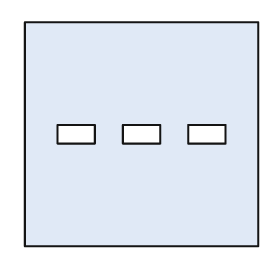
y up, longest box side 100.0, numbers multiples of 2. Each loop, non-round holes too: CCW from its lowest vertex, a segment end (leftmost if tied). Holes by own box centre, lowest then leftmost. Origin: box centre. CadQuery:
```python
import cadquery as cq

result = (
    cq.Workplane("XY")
    .moveTo(-50.0, -48.0)
    .lineTo(50.0, -48.0)
    .lineTo(50.0, 48.0)
    .lineTo(-50.0, 48.0)
    .close()
    .moveTo(-36.0, -4.0)
    .lineTo(-20.0, -4.0)
    .lineTo(-20.0, 4.0)
    .lineTo(-36.0, 4.0)
    .close()
    .moveTo(-8.0, -4.0)
    .lineTo(8.0, -4.0)
    .lineTo(8.0, 4.0)
    .lineTo(-8.0, 4.0)
    .close()
    .moveTo(20.0, -4.0)
    .lineTo(36.0, -4.0)
    .lineTo(36.0, 4.0)
    .lineTo(20.0, 4.0)
    .close()
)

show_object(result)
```